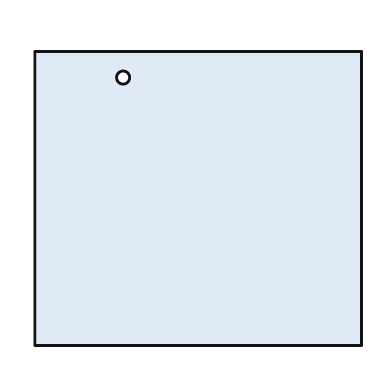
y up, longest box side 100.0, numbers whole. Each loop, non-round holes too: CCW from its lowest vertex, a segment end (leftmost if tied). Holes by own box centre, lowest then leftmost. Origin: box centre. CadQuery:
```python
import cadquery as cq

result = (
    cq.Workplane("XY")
    .moveTo(-50.0, -45.0)
    .lineTo(50.0, -45.0)
    .lineTo(50.0, 45.0)
    .lineTo(-50.0, 45.0)
    .close()
    .moveTo(-23.0, 37.0)
    .circle(2.0)
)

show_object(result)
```